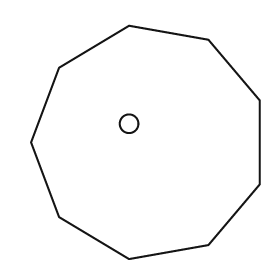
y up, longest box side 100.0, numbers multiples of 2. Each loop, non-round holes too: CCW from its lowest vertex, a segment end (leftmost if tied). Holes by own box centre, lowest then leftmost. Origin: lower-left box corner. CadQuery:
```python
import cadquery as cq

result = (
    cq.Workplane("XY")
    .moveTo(42.0, 0.0)
    .lineTo(76.0, 6.0)
    .lineTo(98.0, 32.0)
    .lineTo(98.0, 68.0)
    .lineTo(76.0, 94.0)
    .lineTo(42.0, 100.0)
    .lineTo(12.0, 82.0)
    .lineTo(0.0, 50.0)
    .lineTo(12.0, 18.0)
    .close()
    .moveTo(42.0, 58.0)
    .circle(4.0)
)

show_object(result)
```